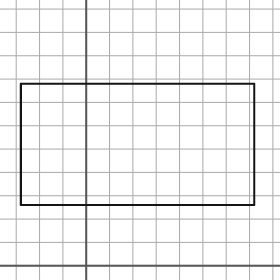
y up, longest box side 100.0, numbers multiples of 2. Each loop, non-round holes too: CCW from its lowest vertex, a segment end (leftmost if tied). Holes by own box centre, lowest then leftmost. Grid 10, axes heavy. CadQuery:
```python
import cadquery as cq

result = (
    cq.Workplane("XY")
    .moveTo(-28.0, 26.0)
    .lineTo(72.0, 26.0)
    .lineTo(72.0, 78.0)
    .lineTo(-28.0, 78.0)
    .close()
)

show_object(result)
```